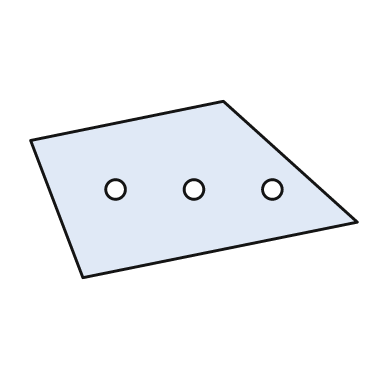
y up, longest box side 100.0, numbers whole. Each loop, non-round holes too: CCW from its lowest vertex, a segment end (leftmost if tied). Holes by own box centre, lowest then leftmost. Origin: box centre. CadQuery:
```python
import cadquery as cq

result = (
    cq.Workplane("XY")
    .moveTo(-34.0, -27.0)
    .lineTo(50.0, -10.0)
    .lineTo(9.0, 27.0)
    .lineTo(-50.0, 15.0)
    .close()
    .moveTo(-24.0, 0.0)
    .circle(3.0)
    .moveTo(0.0, 0.0)
    .circle(3.0)
    .moveTo(24.0, 0.0)
    .circle(3.0)
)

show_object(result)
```